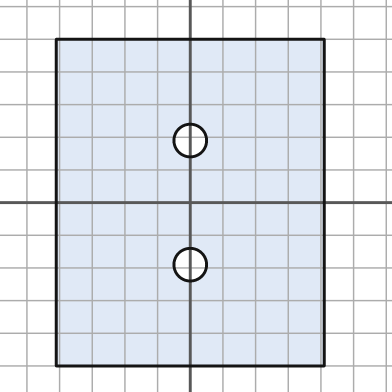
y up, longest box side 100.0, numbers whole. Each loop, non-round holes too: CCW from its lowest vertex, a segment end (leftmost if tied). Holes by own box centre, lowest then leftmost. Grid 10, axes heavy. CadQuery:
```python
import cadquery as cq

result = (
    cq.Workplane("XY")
    .moveTo(-41.0, -50.0)
    .lineTo(41.0, -50.0)
    .lineTo(41.0, 50.0)
    .lineTo(-41.0, 50.0)
    .close()
    .moveTo(0.0, -19.0)
    .circle(5.0)
    .moveTo(0.0, 19.0)
    .circle(5.0)
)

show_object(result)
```